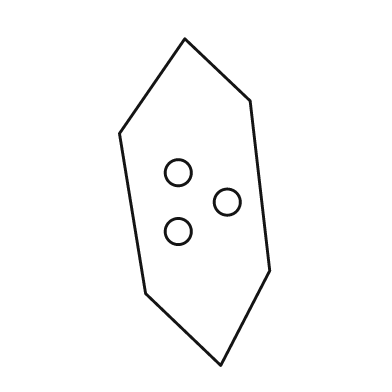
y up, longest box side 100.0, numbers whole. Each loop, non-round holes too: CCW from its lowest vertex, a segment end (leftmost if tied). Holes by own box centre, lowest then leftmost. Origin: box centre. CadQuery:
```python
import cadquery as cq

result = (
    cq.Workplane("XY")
    .moveTo(8.0, -50.0)
    .lineTo(23.0, -21.0)
    .lineTo(17.0, 31.0)
    .lineTo(-3.0, 50.0)
    .lineTo(-23.0, 21.0)
    .lineTo(-15.0, -28.0)
    .close()
    .moveTo(-5.0, -9.0)
    .circle(4.0)
    .moveTo(10.0, 0.0)
    .circle(4.0)
    .moveTo(-5.0, 9.0)
    .circle(4.0)
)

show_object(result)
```